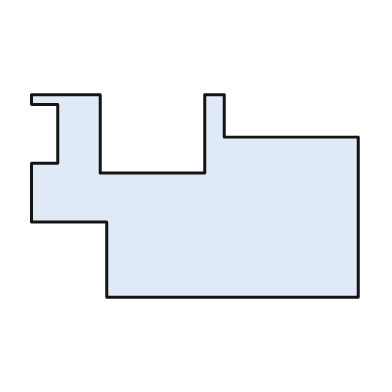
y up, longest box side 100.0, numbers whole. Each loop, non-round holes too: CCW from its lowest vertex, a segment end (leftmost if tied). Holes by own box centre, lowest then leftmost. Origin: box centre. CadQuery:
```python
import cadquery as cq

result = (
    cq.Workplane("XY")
    .moveTo(-27.0, -31.0)
    .lineTo(50.0, -31.0)
    .lineTo(50.0, 18.0)
    .lineTo(9.0, 18.0)
    .lineTo(9.0, 31.0)
    .lineTo(3.0, 31.0)
    .lineTo(3.0, 7.0)
    .lineTo(-29.0, 7.0)
    .lineTo(-29.0, 31.0)
    .lineTo(-50.0, 31.0)
    .lineTo(-50.0, 28.0)
    .lineTo(-42.0, 28.0)
    .lineTo(-42.0, 10.0)
    .lineTo(-50.0, 10.0)
    .lineTo(-50.0, -8.0)
    .lineTo(-27.0, -8.0)
    .close()
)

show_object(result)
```